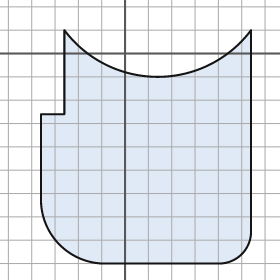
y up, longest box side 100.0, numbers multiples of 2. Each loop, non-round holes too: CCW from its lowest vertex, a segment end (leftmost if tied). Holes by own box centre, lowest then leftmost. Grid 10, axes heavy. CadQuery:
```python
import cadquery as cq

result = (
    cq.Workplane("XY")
    .moveTo(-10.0, -90.0)
    .lineTo(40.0, -90.0)
    .threePointArc((50.0, -86.0), (54.0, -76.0))
    .lineTo(54.0, 10.0)
    .threePointArc((14.0, -10.0), (-26.0, 10.0))
    .lineTo(-26.0, -26.0)
    .lineTo(-36.0, -26.0)
    .lineTo(-36.0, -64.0)
    .threePointArc((-28.0, -82.0), (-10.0, -90.0))
    .close()
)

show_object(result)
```